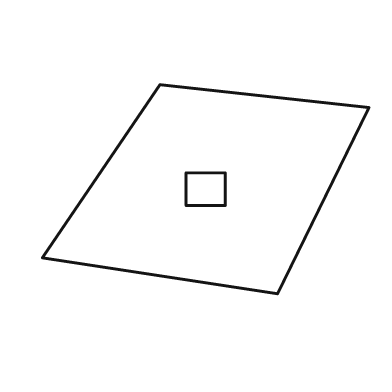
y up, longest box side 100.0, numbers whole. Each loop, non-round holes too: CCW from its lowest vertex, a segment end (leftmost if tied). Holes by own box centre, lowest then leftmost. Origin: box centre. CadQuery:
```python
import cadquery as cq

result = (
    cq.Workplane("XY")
    .moveTo(22.0, -32.0)
    .lineTo(50.0, 25.0)
    .lineTo(-14.0, 32.0)
    .lineTo(-50.0, -21.0)
    .close()
    .moveTo(-6.0, -5.0)
    .lineTo(6.0, -5.0)
    .lineTo(6.0, 5.0)
    .lineTo(-6.0, 5.0)
    .close()
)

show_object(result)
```